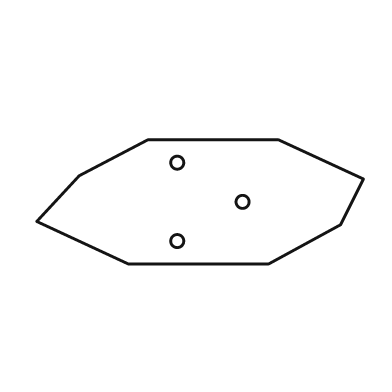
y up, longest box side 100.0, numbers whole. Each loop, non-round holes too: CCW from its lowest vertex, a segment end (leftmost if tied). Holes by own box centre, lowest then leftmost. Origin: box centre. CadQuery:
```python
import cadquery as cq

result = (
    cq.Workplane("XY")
    .moveTo(-22.0, -19.0)
    .lineTo(21.0, -19.0)
    .lineTo(43.0, -7.0)
    .lineTo(50.0, 7.0)
    .lineTo(24.0, 19.0)
    .lineTo(-16.0, 19.0)
    .lineTo(-37.0, 8.0)
    .lineTo(-50.0, -6.0)
    .close()
    .moveTo(-7.0, -12.0)
    .circle(2.0)
    .moveTo(13.0, 0.0)
    .circle(2.0)
    .moveTo(-7.0, 12.0)
    .circle(2.0)
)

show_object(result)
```